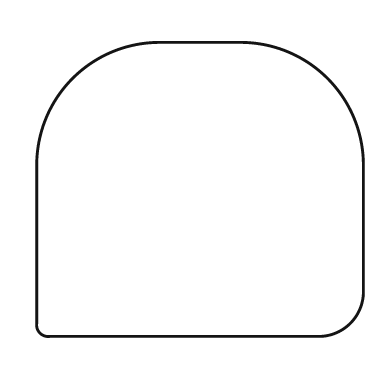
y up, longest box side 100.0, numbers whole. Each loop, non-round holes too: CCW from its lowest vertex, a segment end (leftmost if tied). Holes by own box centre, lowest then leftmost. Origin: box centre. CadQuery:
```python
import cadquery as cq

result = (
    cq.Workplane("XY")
    .moveTo(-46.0, -45.0)
    .lineTo(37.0, -45.0)
    .threePointArc((46.0, -41.0), (50.0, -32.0))
    .lineTo(50.0, 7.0)
    .threePointArc((39.0, 34.0), (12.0, 45.0))
    .lineTo(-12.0, 45.0)
    .threePointArc((-39.0, 34.0), (-50.0, 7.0))
    .lineTo(-50.0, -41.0)
    .threePointArc((-49.0, -44.0), (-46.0, -45.0))
    .close()
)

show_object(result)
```